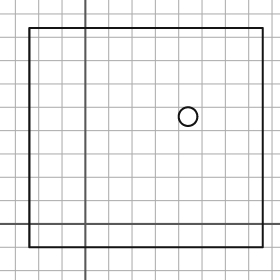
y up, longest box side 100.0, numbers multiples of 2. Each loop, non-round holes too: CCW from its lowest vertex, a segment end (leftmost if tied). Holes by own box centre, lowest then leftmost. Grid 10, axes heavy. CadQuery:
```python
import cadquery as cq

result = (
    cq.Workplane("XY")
    .moveTo(-24.0, -10.0)
    .lineTo(76.0, -10.0)
    .lineTo(76.0, 84.0)
    .lineTo(-24.0, 84.0)
    .close()
    .moveTo(44.0, 46.0)
    .circle(4.0)
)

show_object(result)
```